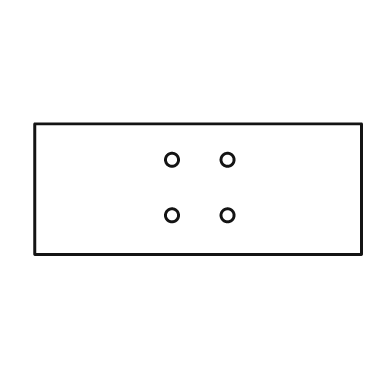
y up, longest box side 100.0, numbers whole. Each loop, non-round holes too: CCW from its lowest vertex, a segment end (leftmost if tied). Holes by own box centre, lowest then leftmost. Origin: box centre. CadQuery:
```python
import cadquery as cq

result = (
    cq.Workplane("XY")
    .moveTo(-50.0, -20.0)
    .lineTo(50.0, -20.0)
    .lineTo(50.0, 20.0)
    .lineTo(-50.0, 20.0)
    .close()
    .moveTo(-8.0, -8.0)
    .circle(2.0)
    .moveTo(9.0, -8.0)
    .circle(2.0)
    .moveTo(-8.0, 9.0)
    .circle(2.0)
    .moveTo(9.0, 9.0)
    .circle(2.0)
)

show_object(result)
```